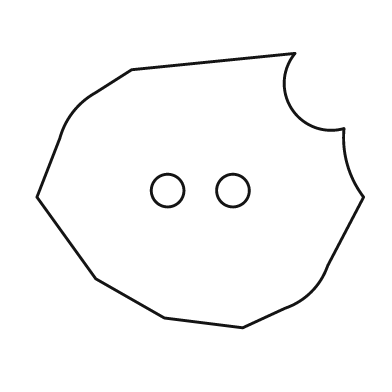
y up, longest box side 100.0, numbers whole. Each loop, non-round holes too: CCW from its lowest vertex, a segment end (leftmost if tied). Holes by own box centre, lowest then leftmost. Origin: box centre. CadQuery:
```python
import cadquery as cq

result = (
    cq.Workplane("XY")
    .moveTo(13.0, -42.0)
    .lineTo(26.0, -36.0)
    .threePointArc((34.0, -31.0), (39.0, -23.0))
    .lineTo(50.0, -2.0)
    .threePointArc((45.0, 8.0), (44.0, 19.0))
    .threePointArc((28.0, 25.0), (29.0, 42.0))
    .lineTo(-21.0, 37.0)
    .lineTo(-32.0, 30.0)
    .threePointArc((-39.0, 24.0), (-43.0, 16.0))
    .lineTo(-50.0, -2.0)
    .lineTo(-32.0, -27.0)
    .lineTo(-11.0, -39.0)
    .close()
    .moveTo(-10.0, 0.0)
    .circle(5.0)
    .moveTo(10.0, 0.0)
    .circle(5.0)
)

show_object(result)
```